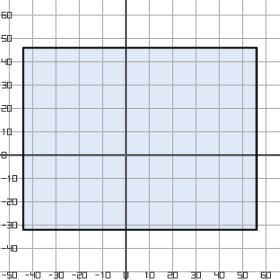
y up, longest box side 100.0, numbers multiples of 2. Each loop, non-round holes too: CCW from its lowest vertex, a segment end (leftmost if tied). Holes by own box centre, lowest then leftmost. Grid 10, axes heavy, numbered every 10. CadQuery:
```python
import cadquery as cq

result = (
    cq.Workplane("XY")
    .moveTo(-44.0, -32.0)
    .lineTo(56.0, -32.0)
    .lineTo(56.0, 46.0)
    .lineTo(-44.0, 46.0)
    .close()
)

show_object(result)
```